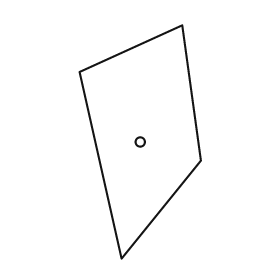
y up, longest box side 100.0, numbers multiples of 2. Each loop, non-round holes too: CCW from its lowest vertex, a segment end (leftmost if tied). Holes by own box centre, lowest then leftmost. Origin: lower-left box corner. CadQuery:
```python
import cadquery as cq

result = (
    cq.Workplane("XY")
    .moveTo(18.0, 0.0)
    .lineTo(52.0, 42.0)
    .lineTo(44.0, 100.0)
    .lineTo(0.0, 80.0)
    .close()
    .moveTo(26.0, 50.0)
    .circle(2.0)
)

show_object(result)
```